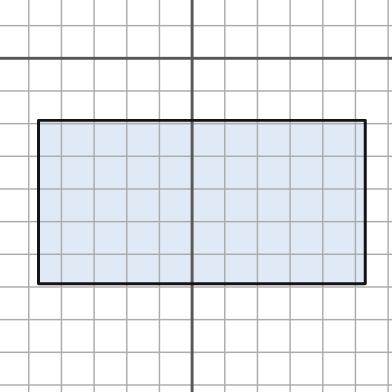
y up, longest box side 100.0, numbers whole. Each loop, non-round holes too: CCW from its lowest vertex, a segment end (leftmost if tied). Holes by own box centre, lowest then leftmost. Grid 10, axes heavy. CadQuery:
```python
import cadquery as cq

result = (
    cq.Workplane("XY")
    .moveTo(-47.0, -69.0)
    .lineTo(53.0, -69.0)
    .lineTo(53.0, -19.0)
    .lineTo(-47.0, -19.0)
    .close()
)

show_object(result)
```